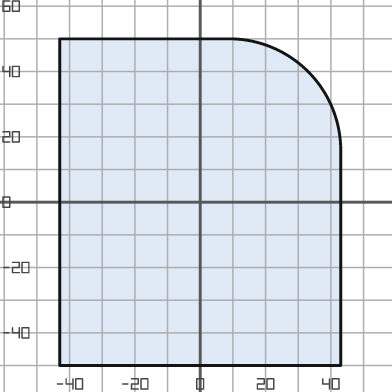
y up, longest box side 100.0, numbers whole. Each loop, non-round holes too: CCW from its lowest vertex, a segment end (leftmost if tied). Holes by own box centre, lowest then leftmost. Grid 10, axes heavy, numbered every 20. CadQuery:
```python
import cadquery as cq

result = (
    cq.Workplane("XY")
    .moveTo(-43.0, -50.0)
    .lineTo(43.0, -50.0)
    .lineTo(43.0, 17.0)
    .threePointArc((33.0, 40.0), (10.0, 50.0))
    .lineTo(-43.0, 50.0)
    .close()
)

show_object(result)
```